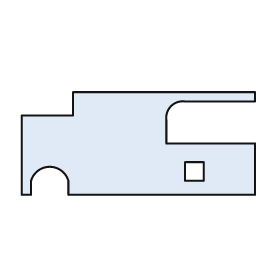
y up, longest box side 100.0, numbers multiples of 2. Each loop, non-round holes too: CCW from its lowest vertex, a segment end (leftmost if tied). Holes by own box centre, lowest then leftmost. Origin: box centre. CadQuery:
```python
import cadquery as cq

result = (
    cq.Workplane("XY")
    .moveTo(-50.0, -22.0)
    .lineTo(-46.0, -22.0)
    .lineTo(-46.0, -16.0)
    .threePointArc((-38.0, -10.0), (-30.0, -16.0))
    .lineTo(-30.0, -22.0)
    .lineTo(50.0, -22.0)
    .lineTo(50.0, 0.0)
    .lineTo(12.0, 0.0)
    .lineTo(12.0, 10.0)
    .threePointArc((14.0, 16.0), (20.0, 18.0))
    .lineTo(50.0, 18.0)
    .lineTo(50.0, 22.0)
    .lineTo(-28.0, 22.0)
    .lineTo(-28.0, 12.0)
    .lineTo(-50.0, 12.0)
    .close()
    .moveTo(20.0, -16.0)
    .lineTo(28.0, -16.0)
    .lineTo(28.0, -8.0)
    .lineTo(20.0, -8.0)
    .close()
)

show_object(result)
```